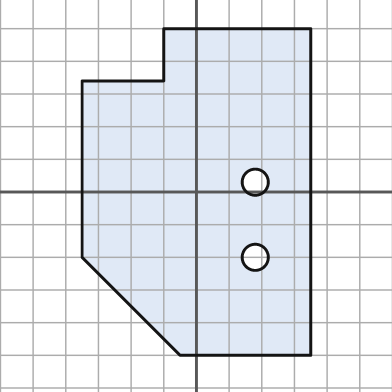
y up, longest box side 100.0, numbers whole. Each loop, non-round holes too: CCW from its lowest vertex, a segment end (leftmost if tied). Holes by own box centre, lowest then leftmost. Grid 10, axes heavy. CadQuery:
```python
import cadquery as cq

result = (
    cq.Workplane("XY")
    .moveTo(-5.0, -50.0)
    .lineTo(35.0, -50.0)
    .lineTo(35.0, 50.0)
    .lineTo(-10.0, 50.0)
    .lineTo(-10.0, 34.0)
    .lineTo(-35.0, 34.0)
    .lineTo(-35.0, -20.0)
    .close()
    .moveTo(18.0, -20.0)
    .circle(4.0)
    .moveTo(18.0, 3.0)
    .circle(4.0)
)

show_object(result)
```